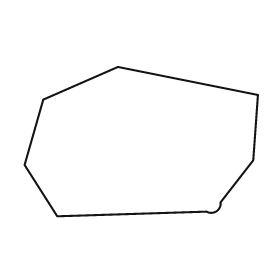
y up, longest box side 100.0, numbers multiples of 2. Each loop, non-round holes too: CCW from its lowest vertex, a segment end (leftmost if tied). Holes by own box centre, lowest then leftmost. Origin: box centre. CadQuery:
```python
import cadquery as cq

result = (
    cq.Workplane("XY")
    .moveTo(-36.0, -32.0)
    .lineTo(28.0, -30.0)
    .threePointArc((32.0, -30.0), (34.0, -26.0))
    .lineTo(48.0, -8.0)
    .lineTo(50.0, 20.0)
    .lineTo(-10.0, 32.0)
    .lineTo(-42.0, 18.0)
    .lineTo(-50.0, -10.0)
    .close()
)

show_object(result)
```